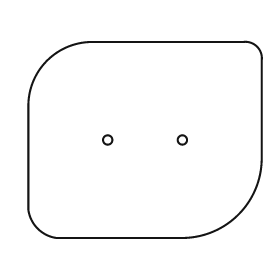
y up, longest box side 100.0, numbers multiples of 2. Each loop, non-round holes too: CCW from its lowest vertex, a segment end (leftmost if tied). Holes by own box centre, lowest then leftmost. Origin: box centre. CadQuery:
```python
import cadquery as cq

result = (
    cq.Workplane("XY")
    .moveTo(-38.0, -42.0)
    .lineTo(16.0, -42.0)
    .threePointArc((40.0, -32.0), (50.0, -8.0))
    .lineTo(50.0, 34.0)
    .threePointArc((48.0, 40.0), (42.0, 42.0))
    .lineTo(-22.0, 42.0)
    .threePointArc((-42.0, 34.0), (-50.0, 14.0))
    .lineTo(-50.0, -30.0)
    .threePointArc((-46.0, -38.0), (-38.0, -42.0))
    .close()
    .moveTo(-16.0, 0.0)
    .circle(2.0)
    .moveTo(16.0, 0.0)
    .circle(2.0)
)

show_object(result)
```